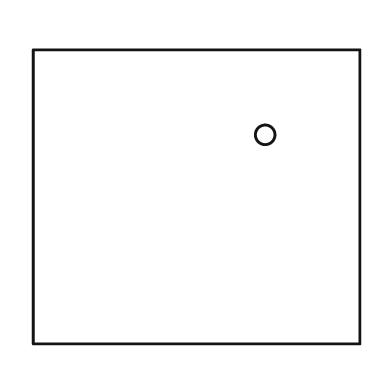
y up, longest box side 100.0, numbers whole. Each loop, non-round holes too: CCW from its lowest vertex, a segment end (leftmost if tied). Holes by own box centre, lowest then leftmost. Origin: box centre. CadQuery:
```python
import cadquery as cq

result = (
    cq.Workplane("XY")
    .moveTo(-50.0, -45.0)
    .lineTo(50.0, -45.0)
    .lineTo(50.0, 45.0)
    .lineTo(-50.0, 45.0)
    .close()
    .moveTo(21.0, 19.0)
    .circle(3.0)
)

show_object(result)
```